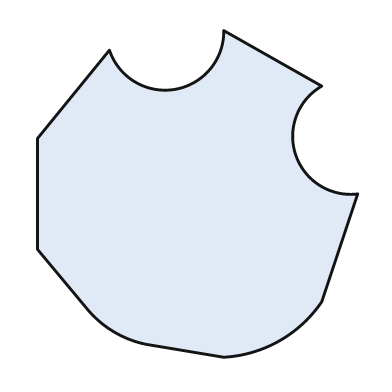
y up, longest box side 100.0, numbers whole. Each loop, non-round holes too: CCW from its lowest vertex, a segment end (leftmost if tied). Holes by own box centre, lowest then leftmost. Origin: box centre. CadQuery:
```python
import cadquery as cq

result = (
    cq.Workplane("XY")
    .moveTo(8.0, -50.0)
    .threePointArc((25.0, -45.0), (38.0, -33.0))
    .lineTo(49.0, 0.0)
    .threePointArc((30.0, 12.0), (38.0, 33.0))
    .lineTo(8.0, 50.0)
    .threePointArc((-7.0, 32.0), (-27.0, 44.0))
    .lineTo(-49.0, 17.0)
    .lineTo(-49.0, -17.0)
    .lineTo(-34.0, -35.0)
    .threePointArc((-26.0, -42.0), (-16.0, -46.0))
    .close()
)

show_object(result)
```